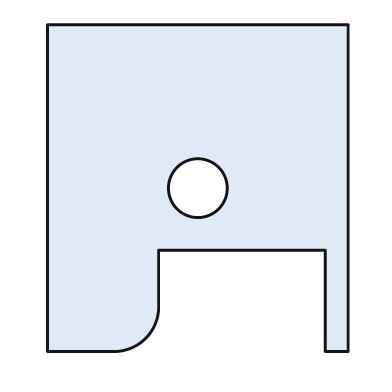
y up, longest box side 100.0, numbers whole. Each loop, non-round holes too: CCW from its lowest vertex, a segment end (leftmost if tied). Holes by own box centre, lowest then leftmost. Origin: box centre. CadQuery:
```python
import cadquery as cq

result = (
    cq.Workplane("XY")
    .moveTo(-46.0, -50.0)
    .lineTo(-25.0, -50.0)
    .threePointArc((-16.0, -46.0), (-12.0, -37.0))
    .lineTo(-12.0, -19.0)
    .lineTo(39.0, -19.0)
    .lineTo(39.0, -50.0)
    .lineTo(46.0, -50.0)
    .lineTo(46.0, 50.0)
    .lineTo(-46.0, 50.0)
    .close()
    .moveTo(0.0, 0.0)
    .circle(9.0)
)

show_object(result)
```